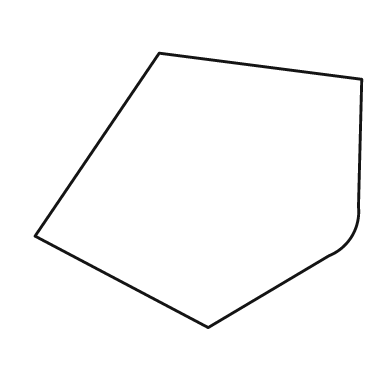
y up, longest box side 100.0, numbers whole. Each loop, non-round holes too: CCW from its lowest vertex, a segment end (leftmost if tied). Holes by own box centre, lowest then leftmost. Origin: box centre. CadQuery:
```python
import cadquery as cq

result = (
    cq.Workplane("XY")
    .moveTo(3.0, -42.0)
    .lineTo(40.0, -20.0)
    .threePointArc((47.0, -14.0), (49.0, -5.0))
    .lineTo(50.0, 34.0)
    .lineTo(-12.0, 42.0)
    .lineTo(-50.0, -14.0)
    .close()
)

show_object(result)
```